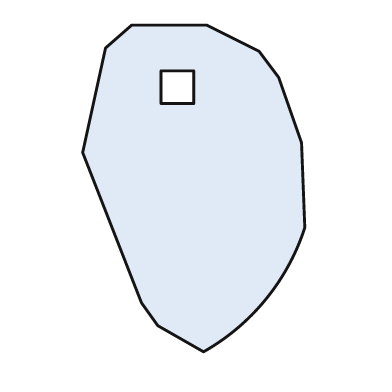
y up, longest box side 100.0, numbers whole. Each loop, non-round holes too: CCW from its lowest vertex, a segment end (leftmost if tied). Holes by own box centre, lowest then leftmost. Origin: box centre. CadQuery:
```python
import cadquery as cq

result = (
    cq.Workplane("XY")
    .moveTo(3.0, -50.0)
    .threePointArc((22.0, -34.0), (34.0, -12.0))
    .lineTo(33.0, 14.0)
    .lineTo(26.0, 34.0)
    .lineTo(20.0, 42.0)
    .lineTo(4.0, 50.0)
    .lineTo(-19.0, 50.0)
    .lineTo(-27.0, 43.0)
    .lineTo(-34.0, 11.0)
    .lineTo(-16.0, -35.0)
    .lineTo(-11.0, -42.0)
    .close()
    .moveTo(-10.0, 26.0)
    .lineTo(0.0, 26.0)
    .lineTo(0.0, 36.0)
    .lineTo(-10.0, 36.0)
    .close()
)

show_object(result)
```